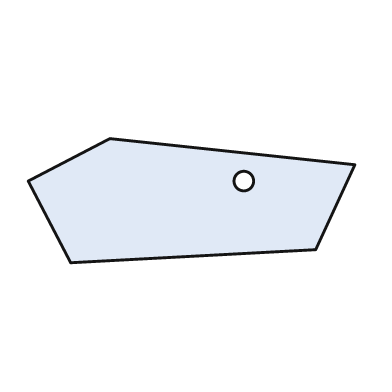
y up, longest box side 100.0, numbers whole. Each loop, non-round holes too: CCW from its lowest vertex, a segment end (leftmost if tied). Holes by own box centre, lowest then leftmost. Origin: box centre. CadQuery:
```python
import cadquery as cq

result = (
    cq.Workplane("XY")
    .moveTo(-37.0, -19.0)
    .lineTo(38.0, -15.0)
    .lineTo(50.0, 11.0)
    .lineTo(-25.0, 19.0)
    .lineTo(-50.0, 6.0)
    .close()
    .moveTo(16.0, 6.0)
    .circle(3.0)
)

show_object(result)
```